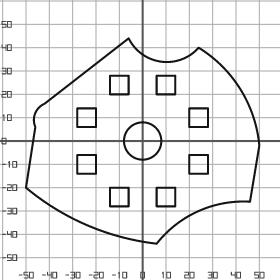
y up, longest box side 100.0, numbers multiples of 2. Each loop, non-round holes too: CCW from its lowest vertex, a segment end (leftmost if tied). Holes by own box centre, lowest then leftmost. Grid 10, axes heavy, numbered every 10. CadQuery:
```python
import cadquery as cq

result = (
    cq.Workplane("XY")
    .moveTo(6.0, -44.0)
    .threePointArc((24.0, -30.0), (46.0, -26.0))
    .lineTo(50.0, -2.0)
    .threePointArc((42.0, 22.0), (24.0, 40.0))
    .threePointArc((8.0, 34.0), (-6.0, 44.0))
    .lineTo(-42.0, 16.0)
    .threePointArc((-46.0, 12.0), (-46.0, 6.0))
    .lineTo(-50.0, -20.0)
    .threePointArc((-24.0, -36.0), (6.0, -44.0))
    .close()
    .moveTo(-14.0, -28.0)
    .lineTo(-6.0, -28.0)
    .lineTo(-6.0, -20.0)
    .lineTo(-14.0, -20.0)
    .close()
    .moveTo(6.0, -28.0)
    .lineTo(14.0, -28.0)
    .lineTo(14.0, -20.0)
    .lineTo(6.0, -20.0)
    .close()
    .moveTo(-28.0, -14.0)
    .lineTo(-20.0, -14.0)
    .lineTo(-20.0, -6.0)
    .lineTo(-28.0, -6.0)
    .close()
    .moveTo(20.0, -14.0)
    .lineTo(28.0, -14.0)
    .lineTo(28.0, -6.0)
    .lineTo(20.0, -6.0)
    .close()
    .moveTo(0.0, 0.0)
    .circle(8.0)
    .moveTo(-28.0, 6.0)
    .lineTo(-20.0, 6.0)
    .lineTo(-20.0, 14.0)
    .lineTo(-28.0, 14.0)
    .close()
    .moveTo(20.0, 6.0)
    .lineTo(28.0, 6.0)
    .lineTo(28.0, 14.0)
    .lineTo(20.0, 14.0)
    .close()
    .moveTo(-14.0, 20.0)
    .lineTo(-6.0, 20.0)
    .lineTo(-6.0, 28.0)
    .lineTo(-14.0, 28.0)
    .close()
    .moveTo(6.0, 20.0)
    .lineTo(14.0, 20.0)
    .lineTo(14.0, 28.0)
    .lineTo(6.0, 28.0)
    .close()
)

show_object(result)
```